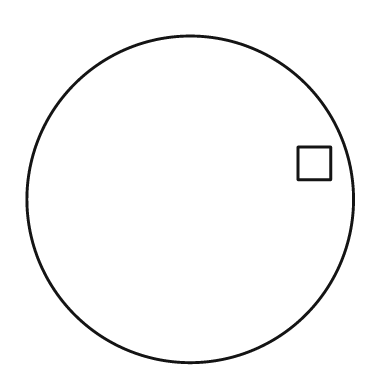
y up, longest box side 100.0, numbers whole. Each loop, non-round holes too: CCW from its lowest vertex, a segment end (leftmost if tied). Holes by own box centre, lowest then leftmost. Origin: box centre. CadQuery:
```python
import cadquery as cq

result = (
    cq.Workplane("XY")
    .moveTo(0.0, 0.0)
    .circle(50.0)
    .moveTo(33.0, 6.0)
    .lineTo(43.0, 6.0)
    .lineTo(43.0, 16.0)
    .lineTo(33.0, 16.0)
    .close()
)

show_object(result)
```